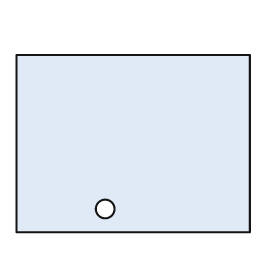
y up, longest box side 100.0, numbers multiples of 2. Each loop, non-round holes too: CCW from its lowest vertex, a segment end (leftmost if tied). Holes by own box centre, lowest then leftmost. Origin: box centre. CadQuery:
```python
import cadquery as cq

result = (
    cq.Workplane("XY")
    .moveTo(-50.0, -38.0)
    .lineTo(50.0, -38.0)
    .lineTo(50.0, 38.0)
    .lineTo(-50.0, 38.0)
    .close()
    .moveTo(-12.0, -28.0)
    .circle(4.0)
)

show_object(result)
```